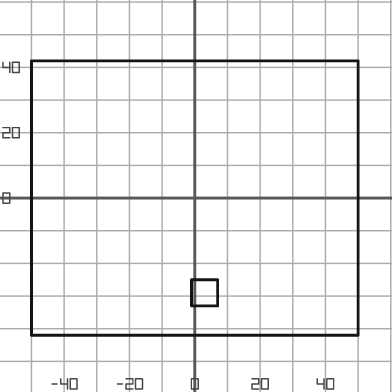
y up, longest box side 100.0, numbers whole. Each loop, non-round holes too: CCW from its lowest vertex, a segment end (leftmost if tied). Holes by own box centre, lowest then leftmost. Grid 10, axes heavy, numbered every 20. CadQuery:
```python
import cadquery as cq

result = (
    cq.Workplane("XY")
    .moveTo(-50.0, -42.0)
    .lineTo(50.0, -42.0)
    .lineTo(50.0, 42.0)
    .lineTo(-50.0, 42.0)
    .close()
    .moveTo(-1.0, -33.0)
    .lineTo(7.0, -33.0)
    .lineTo(7.0, -25.0)
    .lineTo(-1.0, -25.0)
    .close()
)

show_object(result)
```